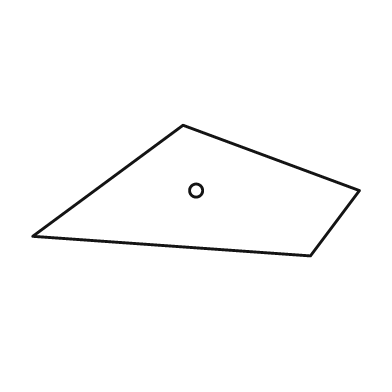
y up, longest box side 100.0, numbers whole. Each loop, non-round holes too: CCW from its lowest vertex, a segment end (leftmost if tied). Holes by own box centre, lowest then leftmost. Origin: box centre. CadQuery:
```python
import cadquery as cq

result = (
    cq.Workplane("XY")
    .moveTo(35.0, -20.0)
    .lineTo(50.0, 0.0)
    .lineTo(-4.0, 20.0)
    .lineTo(-50.0, -14.0)
    .close()
    .moveTo(0.0, 0.0)
    .circle(2.0)
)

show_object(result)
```